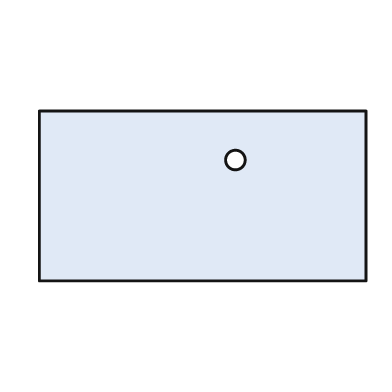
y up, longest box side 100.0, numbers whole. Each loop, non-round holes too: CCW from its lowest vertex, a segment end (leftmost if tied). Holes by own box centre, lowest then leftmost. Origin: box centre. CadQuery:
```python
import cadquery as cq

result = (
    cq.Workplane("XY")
    .moveTo(-50.0, -26.0)
    .lineTo(50.0, -26.0)
    .lineTo(50.0, 26.0)
    .lineTo(-50.0, 26.0)
    .close()
    .moveTo(10.0, 11.0)
    .circle(3.0)
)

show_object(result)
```